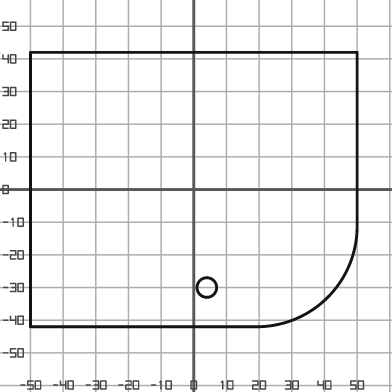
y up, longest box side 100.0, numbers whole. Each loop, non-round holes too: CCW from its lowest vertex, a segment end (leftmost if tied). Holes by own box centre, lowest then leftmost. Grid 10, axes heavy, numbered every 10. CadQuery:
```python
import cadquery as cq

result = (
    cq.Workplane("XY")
    .moveTo(-50.0, -42.0)
    .lineTo(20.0, -42.0)
    .threePointArc((41.0, -33.0), (50.0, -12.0))
    .lineTo(50.0, 42.0)
    .lineTo(-50.0, 42.0)
    .close()
    .moveTo(4.0, -30.0)
    .circle(3.0)
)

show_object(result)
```